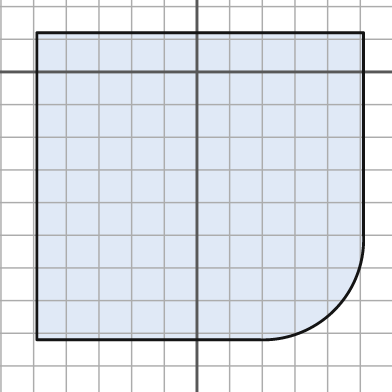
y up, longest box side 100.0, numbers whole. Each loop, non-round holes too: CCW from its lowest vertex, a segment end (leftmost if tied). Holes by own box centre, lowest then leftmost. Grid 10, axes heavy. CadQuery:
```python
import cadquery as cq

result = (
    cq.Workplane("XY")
    .moveTo(-49.0, -82.0)
    .lineTo(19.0, -82.0)
    .threePointArc((42.0, -73.0), (51.0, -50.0))
    .lineTo(51.0, 12.0)
    .lineTo(-49.0, 12.0)
    .close()
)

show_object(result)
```